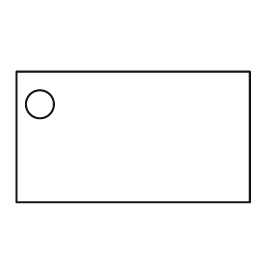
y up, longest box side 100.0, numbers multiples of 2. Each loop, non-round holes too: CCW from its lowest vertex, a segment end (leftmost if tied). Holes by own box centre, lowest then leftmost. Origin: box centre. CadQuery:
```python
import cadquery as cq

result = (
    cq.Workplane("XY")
    .moveTo(-50.0, -28.0)
    .lineTo(50.0, -28.0)
    .lineTo(50.0, 28.0)
    .lineTo(-50.0, 28.0)
    .close()
    .moveTo(-40.0, 14.0)
    .circle(6.0)
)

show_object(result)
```